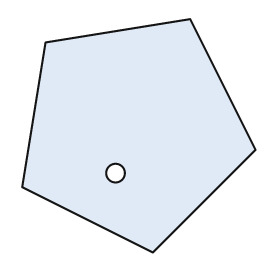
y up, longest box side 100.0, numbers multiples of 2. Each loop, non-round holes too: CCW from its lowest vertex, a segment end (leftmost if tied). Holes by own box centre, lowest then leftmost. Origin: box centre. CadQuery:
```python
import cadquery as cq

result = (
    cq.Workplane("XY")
    .moveTo(6.0, -50.0)
    .lineTo(50.0, -6.0)
    .lineTo(22.0, 50.0)
    .lineTo(-40.0, 40.0)
    .lineTo(-50.0, -22.0)
    .close()
    .moveTo(-10.0, -16.0)
    .circle(4.0)
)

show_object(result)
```